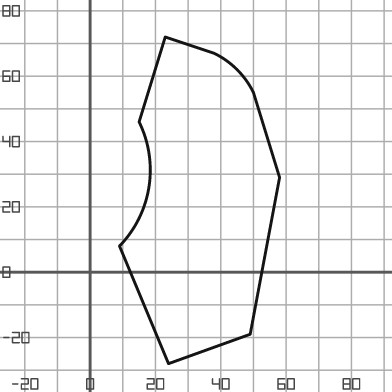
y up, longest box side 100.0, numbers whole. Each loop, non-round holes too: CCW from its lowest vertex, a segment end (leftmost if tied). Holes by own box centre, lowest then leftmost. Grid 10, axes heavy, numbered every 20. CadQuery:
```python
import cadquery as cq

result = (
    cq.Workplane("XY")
    .moveTo(24.0, -28.0)
    .lineTo(49.0, -19.0)
    .lineTo(58.0, 29.0)
    .lineTo(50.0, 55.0)
    .threePointArc((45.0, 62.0), (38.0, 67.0))
    .lineTo(23.0, 72.0)
    .lineTo(15.0, 46.0)
    .threePointArc((18.0, 26.0), (9.0, 8.0))
    .close()
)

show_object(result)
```